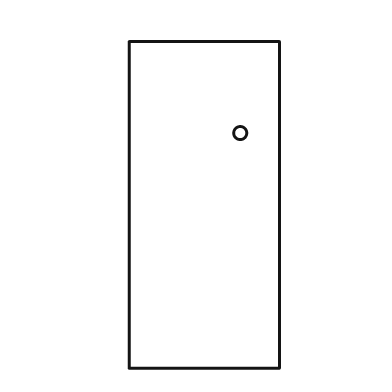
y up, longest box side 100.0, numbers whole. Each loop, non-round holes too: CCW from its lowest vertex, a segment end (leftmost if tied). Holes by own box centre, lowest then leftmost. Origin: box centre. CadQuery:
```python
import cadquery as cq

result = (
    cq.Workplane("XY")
    .moveTo(-23.0, -50.0)
    .lineTo(23.0, -50.0)
    .lineTo(23.0, 50.0)
    .lineTo(-23.0, 50.0)
    .close()
    .moveTo(11.0, 22.0)
    .circle(2.0)
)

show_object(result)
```